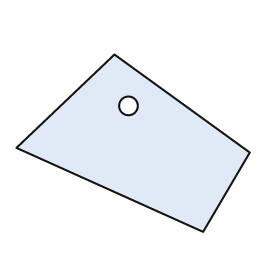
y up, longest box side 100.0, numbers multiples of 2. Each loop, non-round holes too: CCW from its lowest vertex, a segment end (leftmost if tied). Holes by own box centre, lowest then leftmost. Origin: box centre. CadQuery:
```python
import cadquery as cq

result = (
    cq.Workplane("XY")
    .moveTo(30.0, -38.0)
    .lineTo(50.0, -4.0)
    .lineTo(-8.0, 38.0)
    .lineTo(-50.0, -2.0)
    .close()
    .moveTo(-2.0, 16.0)
    .circle(4.0)
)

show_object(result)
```